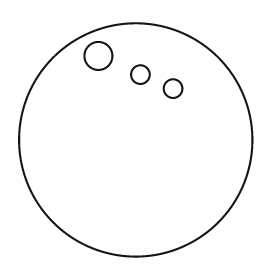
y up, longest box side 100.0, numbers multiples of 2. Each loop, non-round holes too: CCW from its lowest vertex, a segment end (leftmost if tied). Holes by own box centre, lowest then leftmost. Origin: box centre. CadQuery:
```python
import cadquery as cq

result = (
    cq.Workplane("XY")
    .moveTo(0.0, 0.0)
    .circle(50.0)
    .moveTo(16.0, 22.0)
    .circle(4.0)
    .moveTo(2.0, 28.0)
    .circle(4.0)
    .moveTo(-16.0, 36.0)
    .circle(6.0)
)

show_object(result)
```